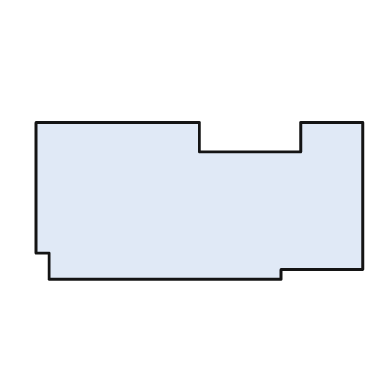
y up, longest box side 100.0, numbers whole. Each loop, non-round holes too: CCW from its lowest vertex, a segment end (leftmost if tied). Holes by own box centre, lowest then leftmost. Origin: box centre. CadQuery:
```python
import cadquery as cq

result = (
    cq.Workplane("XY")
    .moveTo(-46.0, -24.0)
    .lineTo(25.0, -24.0)
    .lineTo(25.0, -21.0)
    .lineTo(50.0, -21.0)
    .lineTo(50.0, 24.0)
    .lineTo(31.0, 24.0)
    .lineTo(31.0, 15.0)
    .lineTo(0.0, 15.0)
    .lineTo(0.0, 24.0)
    .lineTo(-50.0, 24.0)
    .lineTo(-50.0, -16.0)
    .lineTo(-46.0, -16.0)
    .close()
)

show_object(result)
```